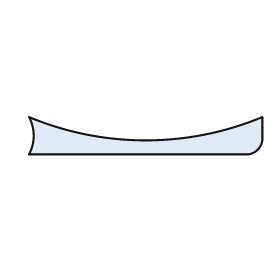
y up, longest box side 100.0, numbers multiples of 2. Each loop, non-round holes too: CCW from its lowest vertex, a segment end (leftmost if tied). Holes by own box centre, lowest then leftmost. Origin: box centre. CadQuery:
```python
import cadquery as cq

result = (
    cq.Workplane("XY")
    .moveTo(-50.0, -8.0)
    .lineTo(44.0, -8.0)
    .threePointArc((48.0, -6.0), (50.0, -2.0))
    .lineTo(50.0, 8.0)
    .threePointArc((0.0, -2.0), (-50.0, 8.0))
    .threePointArc((-48.0, 0.0), (-50.0, -8.0))
    .close()
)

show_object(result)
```